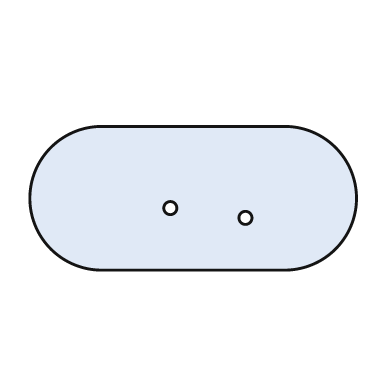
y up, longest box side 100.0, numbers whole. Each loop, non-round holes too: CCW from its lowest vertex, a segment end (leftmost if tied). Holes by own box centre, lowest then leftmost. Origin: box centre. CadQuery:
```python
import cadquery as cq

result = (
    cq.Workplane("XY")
    .moveTo(-28.0, -22.0)
    .lineTo(28.0, -22.0)
    .threePointArc((50.0, 0.0), (28.0, 22.0))
    .lineTo(-28.0, 22.0)
    .threePointArc((-50.0, 0.0), (-28.0, -22.0))
    .close()
    .moveTo(16.0, -6.0)
    .circle(2.0)
    .moveTo(-7.0, -3.0)
    .circle(2.0)
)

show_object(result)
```